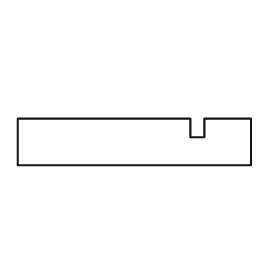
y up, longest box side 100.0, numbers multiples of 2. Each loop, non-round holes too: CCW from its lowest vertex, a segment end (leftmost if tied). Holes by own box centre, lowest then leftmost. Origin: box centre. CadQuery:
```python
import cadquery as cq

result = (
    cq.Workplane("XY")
    .moveTo(-50.0, -10.0)
    .lineTo(50.0, -10.0)
    .lineTo(50.0, 10.0)
    .lineTo(30.0, 10.0)
    .lineTo(30.0, 2.0)
    .lineTo(24.0, 2.0)
    .lineTo(24.0, 10.0)
    .lineTo(-50.0, 10.0)
    .close()
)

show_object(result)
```